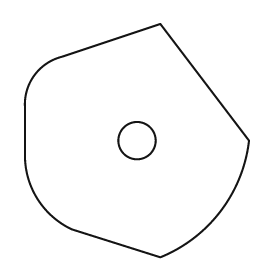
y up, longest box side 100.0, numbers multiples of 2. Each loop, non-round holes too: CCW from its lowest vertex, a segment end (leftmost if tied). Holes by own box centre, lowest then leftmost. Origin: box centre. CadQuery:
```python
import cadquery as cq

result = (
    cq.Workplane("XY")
    .moveTo(10.0, -50.0)
    .threePointArc((36.0, -30.0), (48.0, 0.0))
    .lineTo(10.0, 50.0)
    .lineTo(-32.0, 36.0)
    .threePointArc((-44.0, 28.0), (-48.0, 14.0))
    .lineTo(-48.0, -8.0)
    .threePointArc((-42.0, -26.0), (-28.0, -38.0))
    .close()
    .moveTo(0.0, 0.0)
    .circle(8.0)
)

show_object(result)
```